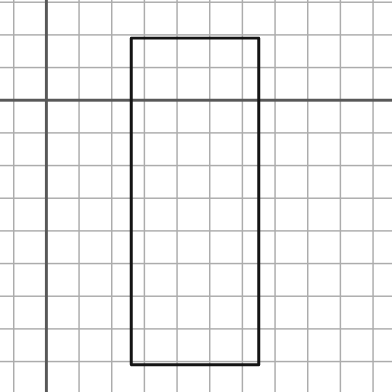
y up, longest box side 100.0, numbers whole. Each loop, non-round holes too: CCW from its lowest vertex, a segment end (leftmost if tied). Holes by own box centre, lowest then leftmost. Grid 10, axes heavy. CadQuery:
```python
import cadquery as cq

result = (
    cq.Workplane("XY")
    .moveTo(26.0, -81.0)
    .lineTo(65.0, -81.0)
    .lineTo(65.0, 19.0)
    .lineTo(26.0, 19.0)
    .close()
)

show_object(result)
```